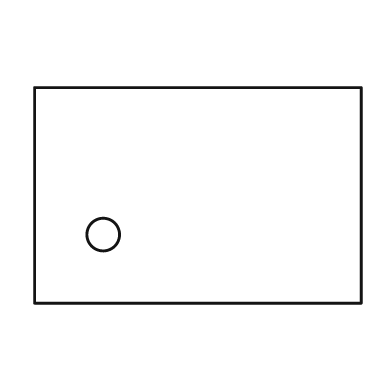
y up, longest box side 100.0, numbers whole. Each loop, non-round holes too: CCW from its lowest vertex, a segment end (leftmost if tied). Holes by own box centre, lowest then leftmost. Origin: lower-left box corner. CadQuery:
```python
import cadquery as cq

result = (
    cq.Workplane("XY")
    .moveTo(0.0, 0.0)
    .lineTo(100.0, 0.0)
    .lineTo(100.0, 66.0)
    .lineTo(0.0, 66.0)
    .close()
    .moveTo(21.0, 21.0)
    .circle(5.0)
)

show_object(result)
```